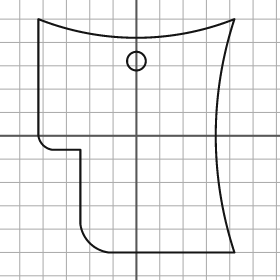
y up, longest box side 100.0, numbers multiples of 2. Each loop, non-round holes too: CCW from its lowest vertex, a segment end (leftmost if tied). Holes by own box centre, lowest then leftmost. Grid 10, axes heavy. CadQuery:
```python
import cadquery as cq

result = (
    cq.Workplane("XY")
    .moveTo(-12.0, -50.0)
    .lineTo(42.0, -50.0)
    .threePointArc((34.0, 0.0), (42.0, 50.0))
    .threePointArc((0.0, 42.0), (-42.0, 50.0))
    .lineTo(-42.0, 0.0)
    .threePointArc((-40.0, -4.0), (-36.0, -6.0))
    .lineTo(-24.0, -6.0)
    .lineTo(-24.0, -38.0)
    .threePointArc((-20.0, -46.0), (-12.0, -50.0))
    .close()
    .moveTo(0.0, 32.0)
    .circle(4.0)
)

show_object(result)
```